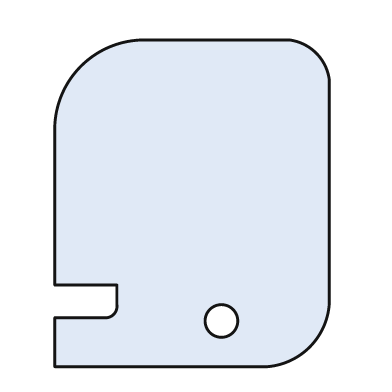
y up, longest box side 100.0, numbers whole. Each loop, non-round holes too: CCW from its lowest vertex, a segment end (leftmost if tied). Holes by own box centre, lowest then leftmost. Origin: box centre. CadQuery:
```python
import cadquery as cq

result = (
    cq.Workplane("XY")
    .moveTo(-42.0, -50.0)
    .lineTo(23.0, -50.0)
    .threePointArc((36.0, -44.0), (42.0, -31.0))
    .lineTo(42.0, 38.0)
    .threePointArc((38.0, 46.0), (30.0, 50.0))
    .lineTo(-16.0, 50.0)
    .threePointArc((-34.0, 42.0), (-42.0, 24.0))
    .lineTo(-42.0, -25.0)
    .lineTo(-23.0, -25.0)
    .lineTo(-23.0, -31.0)
    .threePointArc((-24.0, -34.0), (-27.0, -35.0))
    .lineTo(-42.0, -35.0)
    .close()
    .moveTo(9.0, -36.0)
    .circle(5.0)
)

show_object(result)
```